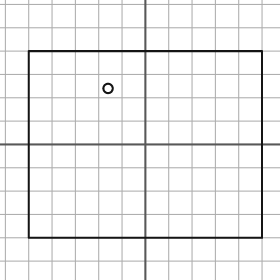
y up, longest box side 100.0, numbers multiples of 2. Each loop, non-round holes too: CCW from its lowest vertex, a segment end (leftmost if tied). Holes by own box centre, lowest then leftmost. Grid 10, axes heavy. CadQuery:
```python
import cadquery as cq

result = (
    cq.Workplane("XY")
    .moveTo(-50.0, -40.0)
    .lineTo(50.0, -40.0)
    .lineTo(50.0, 40.0)
    .lineTo(-50.0, 40.0)
    .close()
    .moveTo(-16.0, 24.0)
    .circle(2.0)
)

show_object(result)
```